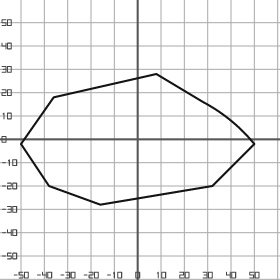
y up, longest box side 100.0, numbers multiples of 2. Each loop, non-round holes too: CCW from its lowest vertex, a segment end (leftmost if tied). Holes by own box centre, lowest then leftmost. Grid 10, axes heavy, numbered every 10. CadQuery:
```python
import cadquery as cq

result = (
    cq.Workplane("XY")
    .moveTo(-16.0, -28.0)
    .lineTo(32.0, -20.0)
    .lineTo(50.0, -2.0)
    .threePointArc((40.0, 8.0), (28.0, 16.0))
    .lineTo(8.0, 28.0)
    .lineTo(-36.0, 18.0)
    .lineTo(-50.0, -2.0)
    .lineTo(-38.0, -20.0)
    .close()
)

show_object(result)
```